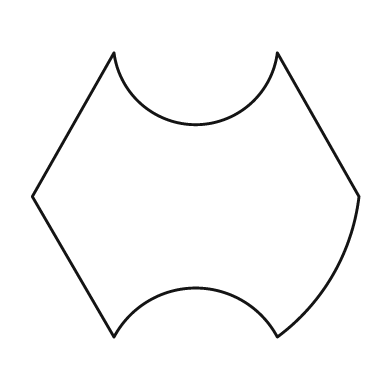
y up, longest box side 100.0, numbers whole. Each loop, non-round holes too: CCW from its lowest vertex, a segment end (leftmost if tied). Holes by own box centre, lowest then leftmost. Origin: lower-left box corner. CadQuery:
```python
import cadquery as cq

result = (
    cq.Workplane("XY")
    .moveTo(25.0, 0.0)
    .threePointArc((50.0, 15.0), (75.0, 0.0))
    .threePointArc((92.0, 19.0), (100.0, 43.0))
    .lineTo(75.0, 87.0)
    .threePointArc((50.0, 65.0), (25.0, 87.0))
    .lineTo(0.0, 43.0)
    .close()
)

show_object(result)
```